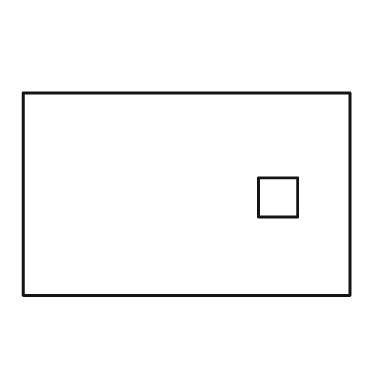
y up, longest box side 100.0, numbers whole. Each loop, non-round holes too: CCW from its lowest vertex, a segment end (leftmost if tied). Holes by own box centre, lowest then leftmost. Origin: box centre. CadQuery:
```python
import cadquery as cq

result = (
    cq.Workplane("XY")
    .moveTo(-50.0, -31.0)
    .lineTo(50.0, -31.0)
    .lineTo(50.0, 31.0)
    .lineTo(-50.0, 31.0)
    .close()
    .moveTo(22.0, -7.0)
    .lineTo(34.0, -7.0)
    .lineTo(34.0, 5.0)
    .lineTo(22.0, 5.0)
    .close()
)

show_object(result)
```